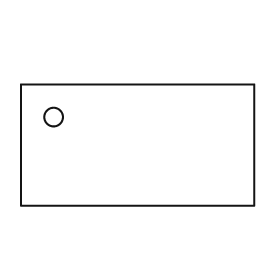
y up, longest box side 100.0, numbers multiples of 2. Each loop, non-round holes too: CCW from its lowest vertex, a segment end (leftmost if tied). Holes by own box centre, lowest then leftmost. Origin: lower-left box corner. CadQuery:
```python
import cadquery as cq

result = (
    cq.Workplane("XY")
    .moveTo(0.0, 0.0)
    .lineTo(100.0, 0.0)
    .lineTo(100.0, 52.0)
    .lineTo(0.0, 52.0)
    .close()
    .moveTo(14.0, 38.0)
    .circle(4.0)
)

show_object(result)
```